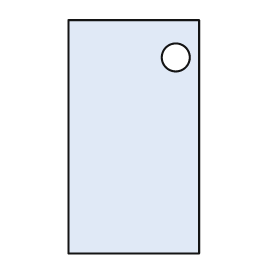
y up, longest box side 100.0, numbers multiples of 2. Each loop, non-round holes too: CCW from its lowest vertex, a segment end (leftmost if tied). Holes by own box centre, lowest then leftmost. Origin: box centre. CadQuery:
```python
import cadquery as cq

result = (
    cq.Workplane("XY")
    .moveTo(-28.0, -50.0)
    .lineTo(28.0, -50.0)
    .lineTo(28.0, 50.0)
    .lineTo(-28.0, 50.0)
    .close()
    .moveTo(18.0, 34.0)
    .circle(6.0)
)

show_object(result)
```